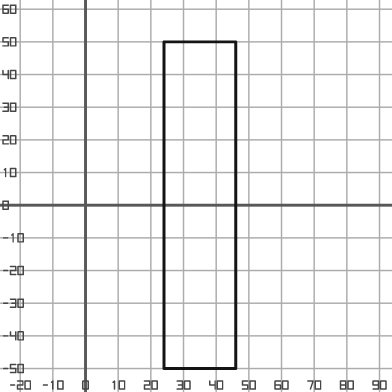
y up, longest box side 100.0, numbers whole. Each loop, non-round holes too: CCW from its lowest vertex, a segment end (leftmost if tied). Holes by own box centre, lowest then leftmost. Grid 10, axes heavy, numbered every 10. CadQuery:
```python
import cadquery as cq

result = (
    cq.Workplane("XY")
    .moveTo(24.0, -50.0)
    .lineTo(46.0, -50.0)
    .lineTo(46.0, 50.0)
    .lineTo(24.0, 50.0)
    .close()
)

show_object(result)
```